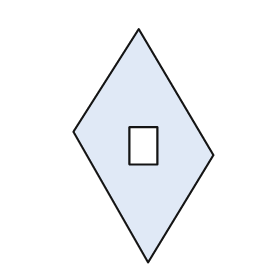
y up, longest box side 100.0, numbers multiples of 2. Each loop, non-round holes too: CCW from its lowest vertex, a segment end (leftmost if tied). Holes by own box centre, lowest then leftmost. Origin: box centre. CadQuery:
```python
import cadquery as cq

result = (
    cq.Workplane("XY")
    .moveTo(2.0, -50.0)
    .lineTo(30.0, -4.0)
    .lineTo(-2.0, 50.0)
    .lineTo(-30.0, 6.0)
    .close()
    .moveTo(-6.0, -8.0)
    .lineTo(6.0, -8.0)
    .lineTo(6.0, 8.0)
    .lineTo(-6.0, 8.0)
    .close()
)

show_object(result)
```